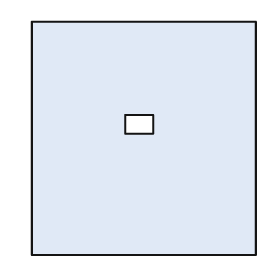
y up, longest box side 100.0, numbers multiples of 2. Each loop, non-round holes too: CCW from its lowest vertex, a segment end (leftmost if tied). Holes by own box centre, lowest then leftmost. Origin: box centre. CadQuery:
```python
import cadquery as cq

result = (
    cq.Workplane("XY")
    .moveTo(-48.0, -50.0)
    .lineTo(48.0, -50.0)
    .lineTo(48.0, 50.0)
    .lineTo(-48.0, 50.0)
    .close()
    .moveTo(-8.0, 2.0)
    .lineTo(4.0, 2.0)
    .lineTo(4.0, 10.0)
    .lineTo(-8.0, 10.0)
    .close()
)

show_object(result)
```